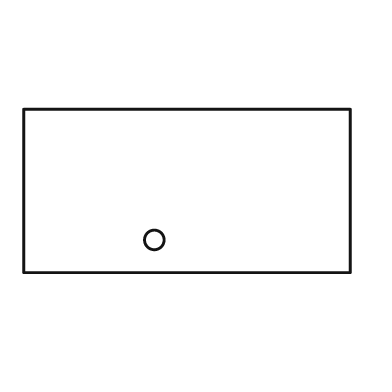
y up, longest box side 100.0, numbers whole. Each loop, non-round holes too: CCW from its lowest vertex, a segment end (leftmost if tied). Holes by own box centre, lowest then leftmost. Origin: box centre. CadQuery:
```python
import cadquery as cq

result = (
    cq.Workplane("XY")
    .moveTo(-50.0, -25.0)
    .lineTo(50.0, -25.0)
    .lineTo(50.0, 25.0)
    .lineTo(-50.0, 25.0)
    .close()
    .moveTo(-10.0, -15.0)
    .circle(3.0)
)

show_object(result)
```